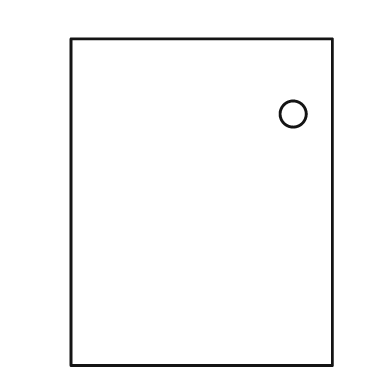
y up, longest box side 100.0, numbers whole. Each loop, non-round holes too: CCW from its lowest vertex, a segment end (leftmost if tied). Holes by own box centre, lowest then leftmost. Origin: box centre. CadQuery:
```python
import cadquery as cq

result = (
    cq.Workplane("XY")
    .moveTo(-40.0, -50.0)
    .lineTo(40.0, -50.0)
    .lineTo(40.0, 50.0)
    .lineTo(-40.0, 50.0)
    .close()
    .moveTo(28.0, 27.0)
    .circle(4.0)
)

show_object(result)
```